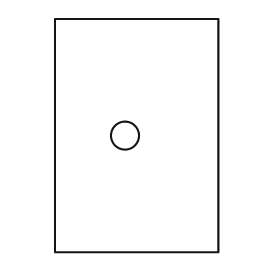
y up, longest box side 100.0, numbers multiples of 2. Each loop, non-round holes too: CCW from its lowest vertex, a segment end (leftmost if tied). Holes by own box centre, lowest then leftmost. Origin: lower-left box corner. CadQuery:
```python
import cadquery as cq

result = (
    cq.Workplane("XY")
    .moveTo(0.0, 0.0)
    .lineTo(70.0, 0.0)
    .lineTo(70.0, 100.0)
    .lineTo(0.0, 100.0)
    .close()
    .moveTo(30.0, 50.0)
    .circle(6.0)
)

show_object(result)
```